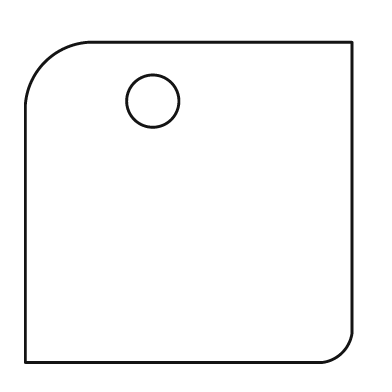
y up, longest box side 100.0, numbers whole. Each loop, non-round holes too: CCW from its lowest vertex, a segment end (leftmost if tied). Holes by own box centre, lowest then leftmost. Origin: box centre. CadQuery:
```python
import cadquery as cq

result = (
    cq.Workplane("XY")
    .moveTo(-50.0, -49.0)
    .lineTo(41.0, -49.0)
    .threePointArc((47.0, -46.0), (50.0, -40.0))
    .lineTo(50.0, 49.0)
    .lineTo(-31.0, 49.0)
    .threePointArc((-44.0, 43.0), (-50.0, 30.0))
    .close()
    .moveTo(-11.0, 31.0)
    .circle(8.0)
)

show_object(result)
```